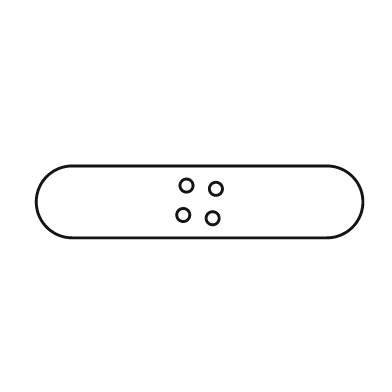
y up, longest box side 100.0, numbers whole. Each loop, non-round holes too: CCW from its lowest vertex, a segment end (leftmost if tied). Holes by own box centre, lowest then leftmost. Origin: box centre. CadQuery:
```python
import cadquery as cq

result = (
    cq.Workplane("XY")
    .moveTo(-39.0, -11.0)
    .lineTo(39.0, -11.0)
    .threePointArc((50.0, 0.0), (39.0, 11.0))
    .lineTo(-39.0, 11.0)
    .threePointArc((-50.0, 0.0), (-39.0, -11.0))
    .close()
    .moveTo(4.0, -5.0)
    .circle(2.0)
    .moveTo(-5.0, -4.0)
    .circle(2.0)
    .moveTo(5.0, 4.0)
    .circle(2.0)
    .moveTo(-4.0, 5.0)
    .circle(2.0)
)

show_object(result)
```